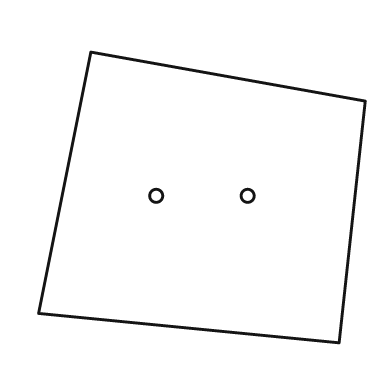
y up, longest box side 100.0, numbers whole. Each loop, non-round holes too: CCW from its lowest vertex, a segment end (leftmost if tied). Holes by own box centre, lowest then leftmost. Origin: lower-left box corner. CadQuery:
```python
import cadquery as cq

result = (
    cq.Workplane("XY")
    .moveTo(92.0, 0.0)
    .lineTo(100.0, 74.0)
    .lineTo(16.0, 89.0)
    .lineTo(0.0, 9.0)
    .close()
    .moveTo(36.0, 45.0)
    .circle(2.0)
    .moveTo(64.0, 45.0)
    .circle(2.0)
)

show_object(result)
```